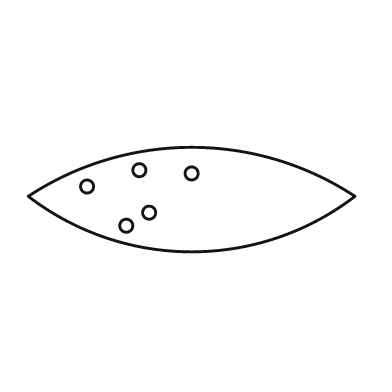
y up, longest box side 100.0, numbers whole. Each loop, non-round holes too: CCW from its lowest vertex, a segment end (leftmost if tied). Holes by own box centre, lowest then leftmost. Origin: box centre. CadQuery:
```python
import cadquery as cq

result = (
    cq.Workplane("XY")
    .moveTo(-50.0, 1.0)
    .threePointArc((0.0, -16.0), (50.0, 1.0))
    .threePointArc((0.0, 16.0), (-50.0, 1.0))
    .close()
    .moveTo(-20.0, -8.0)
    .circle(2.0)
    .moveTo(-13.0, -4.0)
    .circle(2.0)
    .moveTo(-32.0, 4.0)
    .circle(2.0)
    .moveTo(0.0, 8.0)
    .circle(2.0)
    .moveTo(-16.0, 9.0)
    .circle(2.0)
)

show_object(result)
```